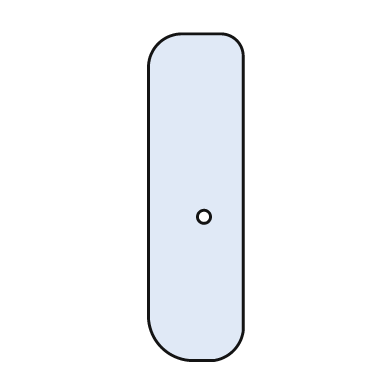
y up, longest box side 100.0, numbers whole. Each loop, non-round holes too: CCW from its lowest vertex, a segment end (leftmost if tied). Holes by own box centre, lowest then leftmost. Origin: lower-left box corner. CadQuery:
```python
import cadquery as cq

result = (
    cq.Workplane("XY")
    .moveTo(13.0, 0.0)
    .lineTo(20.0, 0.0)
    .threePointArc((26.0, 3.0), (29.0, 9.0))
    .lineTo(29.0, 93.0)
    .threePointArc((27.0, 98.0), (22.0, 100.0))
    .lineTo(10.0, 100.0)
    .threePointArc((3.0, 97.0), (0.0, 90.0))
    .lineTo(0.0, 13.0)
    .threePointArc((4.0, 4.0), (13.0, 0.0))
    .close()
    .moveTo(17.0, 44.0)
    .circle(2.0)
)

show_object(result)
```